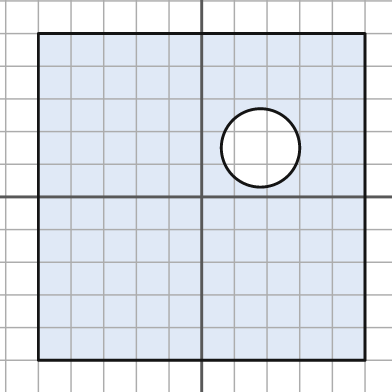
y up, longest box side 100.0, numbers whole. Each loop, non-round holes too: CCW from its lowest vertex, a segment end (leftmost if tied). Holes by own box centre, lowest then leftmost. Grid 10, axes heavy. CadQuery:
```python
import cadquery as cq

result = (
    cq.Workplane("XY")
    .moveTo(-50.0, -50.0)
    .lineTo(50.0, -50.0)
    .lineTo(50.0, 50.0)
    .lineTo(-50.0, 50.0)
    .close()
    .moveTo(18.0, 15.0)
    .circle(12.0)
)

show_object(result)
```